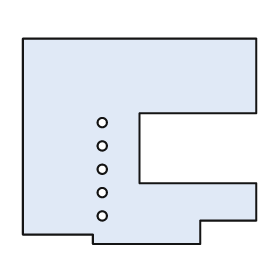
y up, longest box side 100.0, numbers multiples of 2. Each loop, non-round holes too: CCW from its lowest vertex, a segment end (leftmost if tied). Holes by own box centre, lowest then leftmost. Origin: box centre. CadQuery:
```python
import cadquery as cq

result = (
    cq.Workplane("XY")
    .moveTo(-20.0, -44.0)
    .lineTo(26.0, -44.0)
    .lineTo(26.0, -34.0)
    .lineTo(50.0, -34.0)
    .lineTo(50.0, -18.0)
    .lineTo(0.0, -18.0)
    .lineTo(0.0, 12.0)
    .lineTo(50.0, 12.0)
    .lineTo(50.0, 44.0)
    .lineTo(-50.0, 44.0)
    .lineTo(-50.0, -40.0)
    .lineTo(-20.0, -40.0)
    .close()
    .moveTo(-16.0, -32.0)
    .circle(2.0)
    .moveTo(-16.0, -22.0)
    .circle(2.0)
    .moveTo(-16.0, -12.0)
    .circle(2.0)
    .moveTo(-16.0, -2.0)
    .circle(2.0)
    .moveTo(-16.0, 8.0)
    .circle(2.0)
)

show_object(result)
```